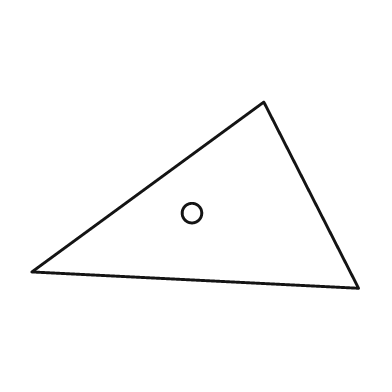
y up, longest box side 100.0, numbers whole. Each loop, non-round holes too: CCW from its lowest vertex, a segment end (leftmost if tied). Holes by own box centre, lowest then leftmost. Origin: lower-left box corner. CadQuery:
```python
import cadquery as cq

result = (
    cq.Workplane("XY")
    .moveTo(100.0, 0.0)
    .lineTo(71.0, 57.0)
    .lineTo(0.0, 5.0)
    .close()
    .moveTo(49.0, 23.0)
    .circle(3.0)
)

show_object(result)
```